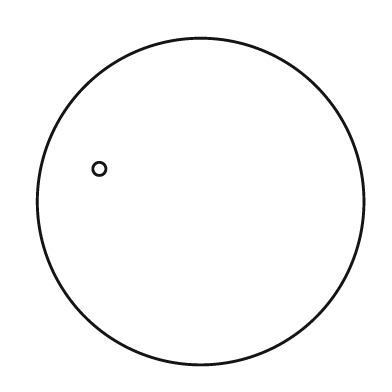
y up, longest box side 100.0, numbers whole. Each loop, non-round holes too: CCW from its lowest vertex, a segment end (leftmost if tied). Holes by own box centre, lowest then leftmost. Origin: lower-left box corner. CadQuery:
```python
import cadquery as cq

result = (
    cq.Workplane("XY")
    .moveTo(50.0, 50.0)
    .circle(50.0)
    .moveTo(19.0, 60.0)
    .circle(2.0)
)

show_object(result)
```